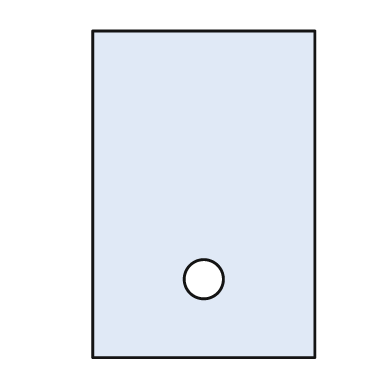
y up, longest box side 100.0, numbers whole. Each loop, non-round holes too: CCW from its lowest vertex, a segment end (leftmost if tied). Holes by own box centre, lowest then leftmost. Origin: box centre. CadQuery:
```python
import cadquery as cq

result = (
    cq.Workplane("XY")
    .moveTo(-34.0, -50.0)
    .lineTo(34.0, -50.0)
    .lineTo(34.0, 50.0)
    .lineTo(-34.0, 50.0)
    .close()
    .moveTo(0.0, -26.0)
    .circle(6.0)
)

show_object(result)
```